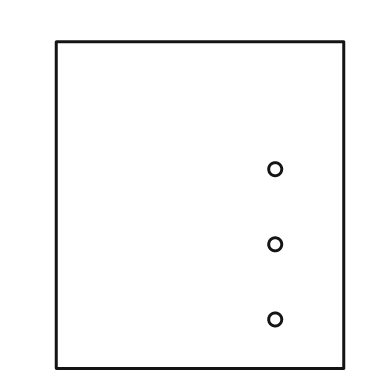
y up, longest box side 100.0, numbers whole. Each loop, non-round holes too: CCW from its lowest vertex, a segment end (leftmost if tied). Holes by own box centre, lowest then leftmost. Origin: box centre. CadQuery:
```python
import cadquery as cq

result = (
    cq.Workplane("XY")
    .moveTo(-44.0, -50.0)
    .lineTo(44.0, -50.0)
    .lineTo(44.0, 50.0)
    .lineTo(-44.0, 50.0)
    .close()
    .moveTo(23.0, -35.0)
    .circle(2.0)
    .moveTo(23.0, -12.0)
    .circle(2.0)
    .moveTo(23.0, 11.0)
    .circle(2.0)
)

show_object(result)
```